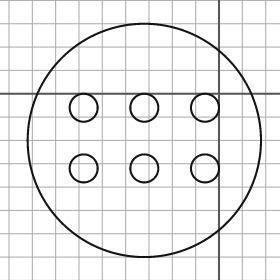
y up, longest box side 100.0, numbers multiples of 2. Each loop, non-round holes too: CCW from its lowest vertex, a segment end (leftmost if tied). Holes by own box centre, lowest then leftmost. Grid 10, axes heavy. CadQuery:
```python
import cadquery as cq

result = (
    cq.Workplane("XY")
    .moveTo(-32.0, -20.0)
    .circle(50.0)
    .moveTo(-58.0, -32.0)
    .circle(6.0)
    .moveTo(-32.0, -32.0)
    .circle(6.0)
    .moveTo(-6.0, -32.0)
    .circle(6.0)
    .moveTo(-58.0, -6.0)
    .circle(6.0)
    .moveTo(-32.0, -6.0)
    .circle(6.0)
    .moveTo(-6.0, -6.0)
    .circle(6.0)
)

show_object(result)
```